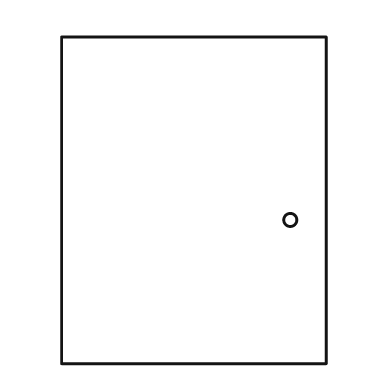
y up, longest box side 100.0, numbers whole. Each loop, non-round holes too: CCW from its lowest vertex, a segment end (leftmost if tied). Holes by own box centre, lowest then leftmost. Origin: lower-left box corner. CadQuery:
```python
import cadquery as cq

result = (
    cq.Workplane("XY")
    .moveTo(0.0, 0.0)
    .lineTo(81.0, 0.0)
    .lineTo(81.0, 100.0)
    .lineTo(0.0, 100.0)
    .close()
    .moveTo(70.0, 44.0)
    .circle(2.0)
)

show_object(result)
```